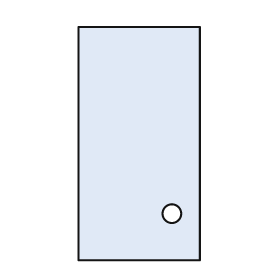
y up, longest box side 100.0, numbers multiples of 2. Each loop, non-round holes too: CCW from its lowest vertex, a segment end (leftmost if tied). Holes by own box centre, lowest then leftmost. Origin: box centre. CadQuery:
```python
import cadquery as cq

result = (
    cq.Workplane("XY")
    .moveTo(-26.0, -50.0)
    .lineTo(26.0, -50.0)
    .lineTo(26.0, 50.0)
    .lineTo(-26.0, 50.0)
    .close()
    .moveTo(14.0, -30.0)
    .circle(4.0)
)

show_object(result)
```